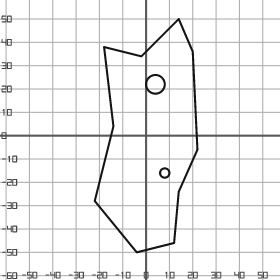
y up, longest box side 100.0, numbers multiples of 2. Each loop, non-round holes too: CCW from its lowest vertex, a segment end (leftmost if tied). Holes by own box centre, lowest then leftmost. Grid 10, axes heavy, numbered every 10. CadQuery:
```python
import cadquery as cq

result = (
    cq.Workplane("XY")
    .moveTo(-4.0, -50.0)
    .lineTo(12.0, -46.0)
    .lineTo(14.0, -24.0)
    .lineTo(22.0, -6.0)
    .lineTo(20.0, 36.0)
    .lineTo(14.0, 50.0)
    .lineTo(-2.0, 34.0)
    .lineTo(-18.0, 38.0)
    .lineTo(-14.0, 4.0)
    .lineTo(-22.0, -28.0)
    .close()
    .moveTo(8.0, -16.0)
    .circle(2.0)
    .moveTo(4.0, 22.0)
    .circle(4.0)
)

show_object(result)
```